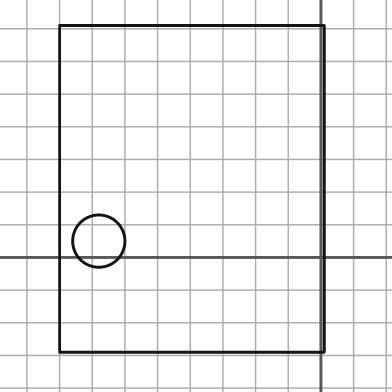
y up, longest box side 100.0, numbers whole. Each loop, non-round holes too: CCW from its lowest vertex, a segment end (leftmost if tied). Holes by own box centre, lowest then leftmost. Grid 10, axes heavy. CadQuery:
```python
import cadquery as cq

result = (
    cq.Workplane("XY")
    .moveTo(-80.0, -29.0)
    .lineTo(1.0, -29.0)
    .lineTo(1.0, 71.0)
    .lineTo(-80.0, 71.0)
    .close()
    .moveTo(-68.0, 5.0)
    .circle(8.0)
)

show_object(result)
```